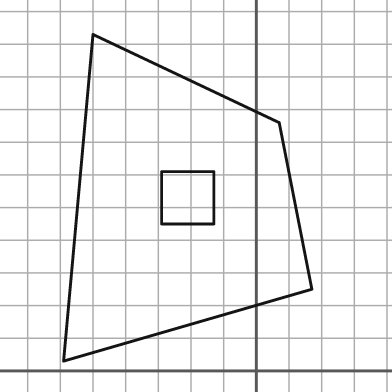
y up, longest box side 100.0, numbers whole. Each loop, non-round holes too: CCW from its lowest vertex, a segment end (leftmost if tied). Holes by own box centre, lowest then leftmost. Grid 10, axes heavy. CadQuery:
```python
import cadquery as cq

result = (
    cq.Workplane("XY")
    .moveTo(-59.0, 3.0)
    .lineTo(17.0, 25.0)
    .lineTo(7.0, 76.0)
    .lineTo(-50.0, 103.0)
    .close()
    .moveTo(-29.0, 45.0)
    .lineTo(-13.0, 45.0)
    .lineTo(-13.0, 61.0)
    .lineTo(-29.0, 61.0)
    .close()
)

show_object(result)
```